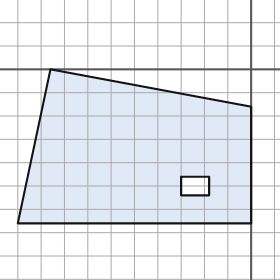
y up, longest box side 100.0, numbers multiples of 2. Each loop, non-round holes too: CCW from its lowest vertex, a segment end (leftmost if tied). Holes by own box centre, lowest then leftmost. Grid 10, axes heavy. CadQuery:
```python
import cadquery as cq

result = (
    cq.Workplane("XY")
    .moveTo(-100.0, -66.0)
    .lineTo(0.0, -66.0)
    .lineTo(0.0, -16.0)
    .lineTo(-86.0, 0.0)
    .close()
    .moveTo(-30.0, -54.0)
    .lineTo(-18.0, -54.0)
    .lineTo(-18.0, -46.0)
    .lineTo(-30.0, -46.0)
    .close()
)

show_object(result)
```